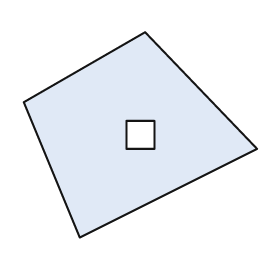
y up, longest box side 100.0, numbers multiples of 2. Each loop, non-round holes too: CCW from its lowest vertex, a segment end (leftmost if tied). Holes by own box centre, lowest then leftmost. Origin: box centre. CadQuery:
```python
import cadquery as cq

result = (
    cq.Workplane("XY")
    .moveTo(-26.0, -44.0)
    .lineTo(50.0, -6.0)
    .lineTo(2.0, 44.0)
    .lineTo(-50.0, 14.0)
    .close()
    .moveTo(-6.0, -6.0)
    .lineTo(6.0, -6.0)
    .lineTo(6.0, 6.0)
    .lineTo(-6.0, 6.0)
    .close()
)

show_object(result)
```